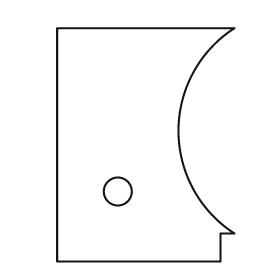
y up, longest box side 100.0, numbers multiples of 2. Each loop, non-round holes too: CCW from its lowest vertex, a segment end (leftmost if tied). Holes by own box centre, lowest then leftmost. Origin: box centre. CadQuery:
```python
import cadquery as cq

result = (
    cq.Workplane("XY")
    .moveTo(-38.0, -50.0)
    .lineTo(32.0, -50.0)
    .lineTo(32.0, -38.0)
    .lineTo(38.0, -38.0)
    .threePointArc((14.0, 6.0), (38.0, 50.0))
    .lineTo(-38.0, 50.0)
    .close()
    .moveTo(-12.0, -20.0)
    .circle(6.0)
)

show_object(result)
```